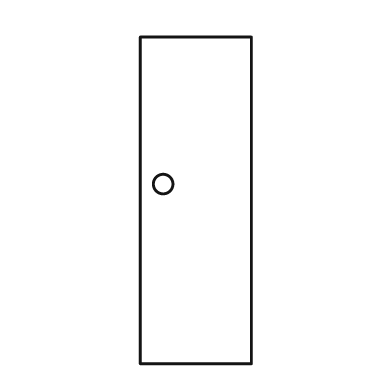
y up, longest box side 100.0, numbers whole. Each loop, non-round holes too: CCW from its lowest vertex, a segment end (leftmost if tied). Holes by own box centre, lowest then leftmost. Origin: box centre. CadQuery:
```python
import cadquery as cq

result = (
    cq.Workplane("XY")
    .moveTo(-17.0, -50.0)
    .lineTo(17.0, -50.0)
    .lineTo(17.0, 50.0)
    .lineTo(-17.0, 50.0)
    .close()
    .moveTo(-10.0, 5.0)
    .circle(3.0)
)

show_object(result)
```